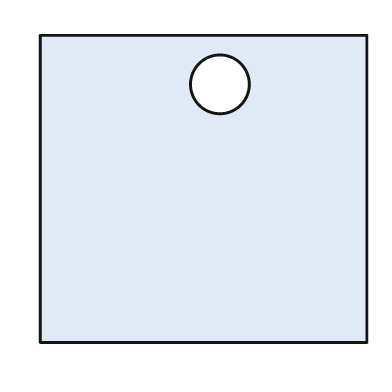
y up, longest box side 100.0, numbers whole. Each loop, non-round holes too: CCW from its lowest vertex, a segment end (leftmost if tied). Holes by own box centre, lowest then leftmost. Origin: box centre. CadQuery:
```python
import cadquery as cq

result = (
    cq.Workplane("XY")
    .moveTo(-50.0, -47.0)
    .lineTo(50.0, -47.0)
    .lineTo(50.0, 47.0)
    .lineTo(-50.0, 47.0)
    .close()
    .moveTo(5.0, 32.0)
    .circle(9.0)
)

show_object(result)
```